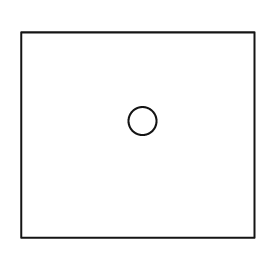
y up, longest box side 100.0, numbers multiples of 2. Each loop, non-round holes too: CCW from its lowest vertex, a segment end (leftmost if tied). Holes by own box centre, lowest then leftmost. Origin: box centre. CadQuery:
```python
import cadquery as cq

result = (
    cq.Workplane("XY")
    .moveTo(-50.0, -44.0)
    .lineTo(50.0, -44.0)
    .lineTo(50.0, 44.0)
    .lineTo(-50.0, 44.0)
    .close()
    .moveTo(2.0, 6.0)
    .circle(6.0)
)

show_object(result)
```